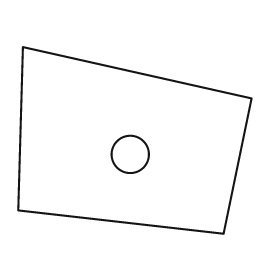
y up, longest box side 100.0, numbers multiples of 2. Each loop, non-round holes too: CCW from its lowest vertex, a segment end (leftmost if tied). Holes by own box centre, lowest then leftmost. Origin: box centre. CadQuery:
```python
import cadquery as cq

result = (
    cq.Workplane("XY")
    .moveTo(38.0, -40.0)
    .lineTo(50.0, 18.0)
    .lineTo(-48.0, 40.0)
    .lineTo(-50.0, -30.0)
    .close()
    .moveTo(-2.0, -6.0)
    .circle(8.0)
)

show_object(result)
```